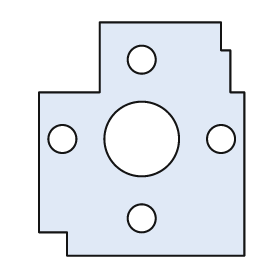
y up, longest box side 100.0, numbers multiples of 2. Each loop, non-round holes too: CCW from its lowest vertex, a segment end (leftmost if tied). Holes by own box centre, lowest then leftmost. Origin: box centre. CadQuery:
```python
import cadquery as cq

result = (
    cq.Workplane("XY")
    .moveTo(-32.0, -50.0)
    .lineTo(44.0, -50.0)
    .lineTo(44.0, 20.0)
    .lineTo(38.0, 20.0)
    .lineTo(38.0, 38.0)
    .lineTo(34.0, 38.0)
    .lineTo(34.0, 50.0)
    .lineTo(-18.0, 50.0)
    .lineTo(-18.0, 20.0)
    .lineTo(-44.0, 20.0)
    .lineTo(-44.0, -40.0)
    .lineTo(-32.0, -40.0)
    .close()
    .moveTo(0.0, -34.0)
    .circle(6.0)
    .moveTo(-34.0, 0.0)
    .circle(6.0)
    .moveTo(0.0, 0.0)
    .circle(16.0)
    .moveTo(34.0, 0.0)
    .circle(6.0)
    .moveTo(0.0, 34.0)
    .circle(6.0)
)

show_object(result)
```